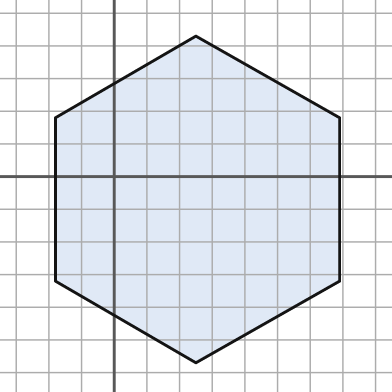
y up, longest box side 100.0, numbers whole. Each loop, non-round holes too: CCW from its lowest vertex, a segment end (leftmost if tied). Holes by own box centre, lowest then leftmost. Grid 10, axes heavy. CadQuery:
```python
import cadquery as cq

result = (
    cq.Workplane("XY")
    .moveTo(25.0, -57.0)
    .lineTo(69.0, -32.0)
    .lineTo(69.0, 18.0)
    .lineTo(25.0, 43.0)
    .lineTo(-18.0, 18.0)
    .lineTo(-18.0, -32.0)
    .close()
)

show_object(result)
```